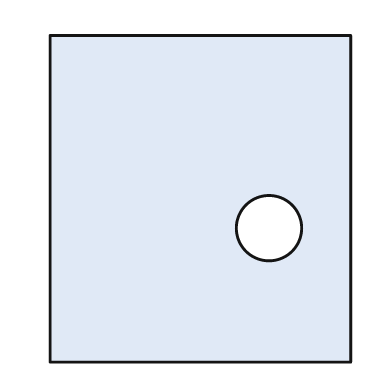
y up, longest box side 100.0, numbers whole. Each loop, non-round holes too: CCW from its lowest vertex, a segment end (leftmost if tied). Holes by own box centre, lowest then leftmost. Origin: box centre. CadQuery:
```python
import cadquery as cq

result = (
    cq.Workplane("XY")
    .moveTo(-46.0, -50.0)
    .lineTo(46.0, -50.0)
    .lineTo(46.0, 50.0)
    .lineTo(-46.0, 50.0)
    .close()
    .moveTo(21.0, -9.0)
    .circle(10.0)
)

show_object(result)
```